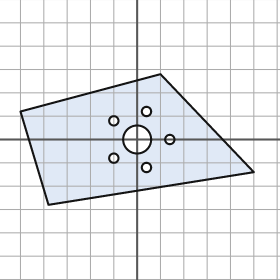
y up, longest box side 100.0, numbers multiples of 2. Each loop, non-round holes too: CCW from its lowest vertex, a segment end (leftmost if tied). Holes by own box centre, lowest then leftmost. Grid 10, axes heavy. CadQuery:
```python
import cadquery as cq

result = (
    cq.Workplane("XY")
    .moveTo(-38.0, -28.0)
    .lineTo(50.0, -14.0)
    .lineTo(10.0, 28.0)
    .lineTo(-50.0, 12.0)
    .close()
    .moveTo(4.0, -12.0)
    .circle(2.0)
    .moveTo(-10.0, -8.0)
    .circle(2.0)
    .moveTo(0.0, 0.0)
    .circle(6.0)
    .moveTo(14.0, 0.0)
    .circle(2.0)
    .moveTo(-10.0, 8.0)
    .circle(2.0)
    .moveTo(4.0, 12.0)
    .circle(2.0)
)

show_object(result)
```